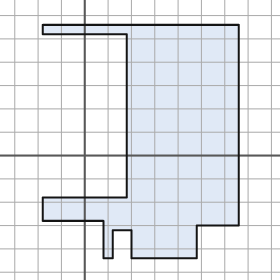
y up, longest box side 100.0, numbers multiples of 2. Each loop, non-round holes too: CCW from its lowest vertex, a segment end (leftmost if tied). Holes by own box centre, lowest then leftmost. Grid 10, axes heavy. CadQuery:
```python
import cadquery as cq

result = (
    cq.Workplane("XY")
    .moveTo(8.0, -44.0)
    .lineTo(12.0, -44.0)
    .lineTo(12.0, -32.0)
    .lineTo(20.0, -32.0)
    .lineTo(20.0, -44.0)
    .lineTo(48.0, -44.0)
    .lineTo(48.0, -30.0)
    .lineTo(66.0, -30.0)
    .lineTo(66.0, 56.0)
    .lineTo(-18.0, 56.0)
    .lineTo(-18.0, 52.0)
    .lineTo(18.0, 52.0)
    .lineTo(18.0, -18.0)
    .lineTo(-18.0, -18.0)
    .lineTo(-18.0, -28.0)
    .lineTo(8.0, -28.0)
    .close()
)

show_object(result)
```